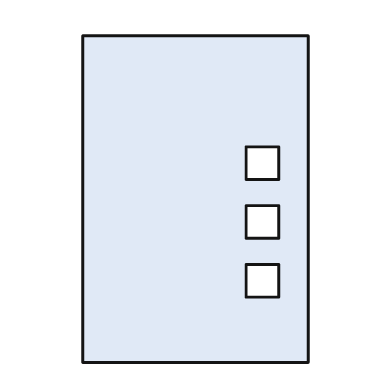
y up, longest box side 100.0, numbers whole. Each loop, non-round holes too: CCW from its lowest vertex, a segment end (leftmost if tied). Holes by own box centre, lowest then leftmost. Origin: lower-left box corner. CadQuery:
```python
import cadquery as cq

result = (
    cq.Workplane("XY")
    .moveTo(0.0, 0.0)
    .lineTo(69.0, 0.0)
    .lineTo(69.0, 100.0)
    .lineTo(0.0, 100.0)
    .close()
    .moveTo(50.0, 20.0)
    .lineTo(60.0, 20.0)
    .lineTo(60.0, 30.0)
    .lineTo(50.0, 30.0)
    .close()
    .moveTo(50.0, 38.0)
    .lineTo(60.0, 38.0)
    .lineTo(60.0, 48.0)
    .lineTo(50.0, 48.0)
    .close()
    .moveTo(50.0, 56.0)
    .lineTo(60.0, 56.0)
    .lineTo(60.0, 66.0)
    .lineTo(50.0, 66.0)
    .close()
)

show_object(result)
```